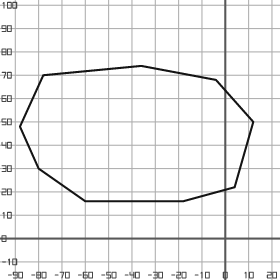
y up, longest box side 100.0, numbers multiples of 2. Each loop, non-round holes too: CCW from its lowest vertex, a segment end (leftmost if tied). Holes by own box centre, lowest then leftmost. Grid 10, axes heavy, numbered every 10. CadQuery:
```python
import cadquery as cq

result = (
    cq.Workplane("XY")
    .moveTo(-60.0, 16.0)
    .lineTo(-18.0, 16.0)
    .lineTo(4.0, 22.0)
    .lineTo(12.0, 50.0)
    .lineTo(-4.0, 68.0)
    .lineTo(-36.0, 74.0)
    .lineTo(-78.0, 70.0)
    .lineTo(-88.0, 48.0)
    .lineTo(-80.0, 30.0)
    .close()
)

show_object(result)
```